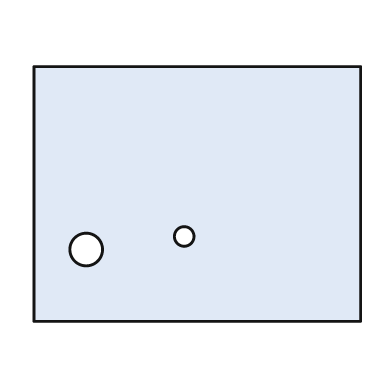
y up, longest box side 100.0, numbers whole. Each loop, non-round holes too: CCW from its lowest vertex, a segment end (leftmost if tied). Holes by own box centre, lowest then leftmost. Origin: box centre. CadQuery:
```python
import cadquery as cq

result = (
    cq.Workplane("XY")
    .moveTo(-50.0, -39.0)
    .lineTo(50.0, -39.0)
    .lineTo(50.0, 39.0)
    .lineTo(-50.0, 39.0)
    .close()
    .moveTo(-34.0, -17.0)
    .circle(5.0)
    .moveTo(-4.0, -13.0)
    .circle(3.0)
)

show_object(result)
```